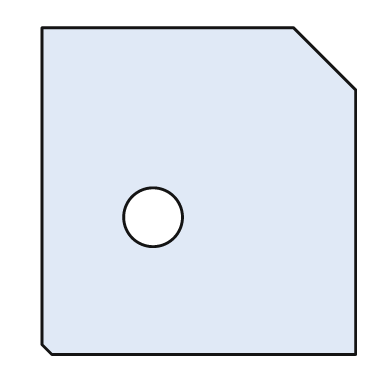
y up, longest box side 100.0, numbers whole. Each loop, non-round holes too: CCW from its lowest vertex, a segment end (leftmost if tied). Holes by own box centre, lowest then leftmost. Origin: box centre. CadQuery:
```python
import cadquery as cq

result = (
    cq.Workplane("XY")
    .moveTo(-45.0, -50.0)
    .lineTo(48.0, -50.0)
    .lineTo(48.0, 31.0)
    .lineTo(29.0, 50.0)
    .lineTo(-48.0, 50.0)
    .lineTo(-48.0, -47.0)
    .close()
    .moveTo(-14.0, -8.0)
    .circle(9.0)
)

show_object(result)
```